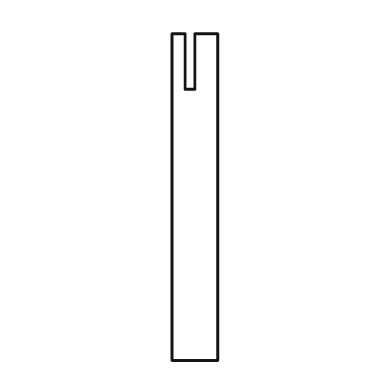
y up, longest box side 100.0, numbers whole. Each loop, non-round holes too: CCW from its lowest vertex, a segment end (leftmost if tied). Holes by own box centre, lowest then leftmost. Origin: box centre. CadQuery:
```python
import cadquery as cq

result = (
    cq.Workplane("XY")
    .moveTo(-7.0, -50.0)
    .lineTo(7.0, -50.0)
    .lineTo(7.0, 50.0)
    .lineTo(0.0, 50.0)
    .lineTo(0.0, 33.0)
    .lineTo(-3.0, 33.0)
    .lineTo(-3.0, 50.0)
    .lineTo(-7.0, 50.0)
    .close()
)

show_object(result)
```